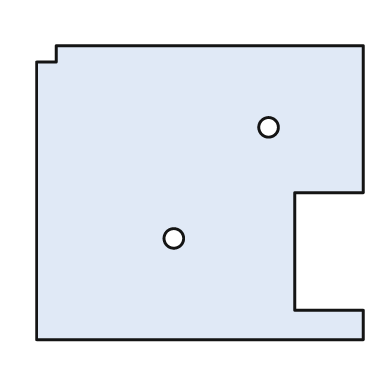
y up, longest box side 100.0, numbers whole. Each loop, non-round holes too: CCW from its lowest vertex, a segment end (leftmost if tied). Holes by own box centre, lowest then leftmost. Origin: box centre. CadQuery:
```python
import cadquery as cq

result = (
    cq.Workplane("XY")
    .moveTo(-50.0, -45.0)
    .lineTo(50.0, -45.0)
    .lineTo(50.0, -36.0)
    .lineTo(29.0, -36.0)
    .lineTo(29.0, 0.0)
    .lineTo(50.0, 0.0)
    .lineTo(50.0, 45.0)
    .lineTo(-44.0, 45.0)
    .lineTo(-44.0, 40.0)
    .lineTo(-50.0, 40.0)
    .close()
    .moveTo(-8.0, -14.0)
    .circle(3.0)
    .moveTo(21.0, 20.0)
    .circle(3.0)
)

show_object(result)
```